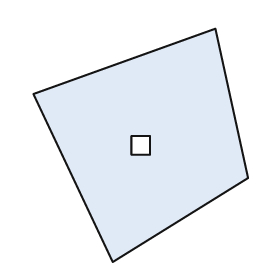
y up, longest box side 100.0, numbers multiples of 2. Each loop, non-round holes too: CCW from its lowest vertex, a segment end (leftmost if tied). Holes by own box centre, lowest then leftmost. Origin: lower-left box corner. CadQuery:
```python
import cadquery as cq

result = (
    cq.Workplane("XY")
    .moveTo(34.0, 0.0)
    .lineTo(92.0, 36.0)
    .lineTo(78.0, 100.0)
    .lineTo(0.0, 72.0)
    .close()
    .moveTo(42.0, 46.0)
    .lineTo(50.0, 46.0)
    .lineTo(50.0, 54.0)
    .lineTo(42.0, 54.0)
    .close()
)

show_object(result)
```